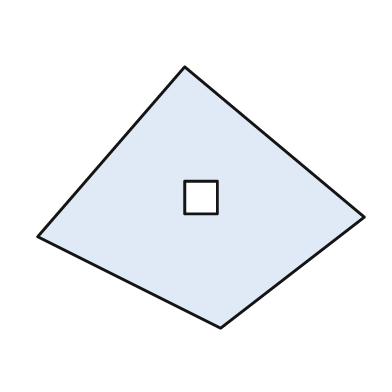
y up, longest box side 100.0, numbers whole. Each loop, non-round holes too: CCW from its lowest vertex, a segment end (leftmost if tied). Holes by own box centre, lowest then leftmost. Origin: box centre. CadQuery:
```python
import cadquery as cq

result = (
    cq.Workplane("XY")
    .moveTo(6.0, -40.0)
    .lineTo(50.0, -6.0)
    .lineTo(-5.0, 40.0)
    .lineTo(-50.0, -12.0)
    .close()
    .moveTo(-5.0, -5.0)
    .lineTo(5.0, -5.0)
    .lineTo(5.0, 5.0)
    .lineTo(-5.0, 5.0)
    .close()
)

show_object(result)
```